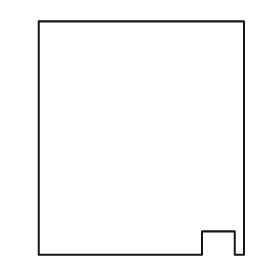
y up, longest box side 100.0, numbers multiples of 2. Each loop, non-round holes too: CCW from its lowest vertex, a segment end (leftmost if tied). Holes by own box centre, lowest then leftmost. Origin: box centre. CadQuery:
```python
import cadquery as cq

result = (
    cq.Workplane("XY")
    .moveTo(-44.0, -50.0)
    .lineTo(26.0, -50.0)
    .lineTo(26.0, -40.0)
    .lineTo(40.0, -40.0)
    .lineTo(40.0, -50.0)
    .lineTo(44.0, -50.0)
    .lineTo(44.0, 50.0)
    .lineTo(-44.0, 50.0)
    .close()
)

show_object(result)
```